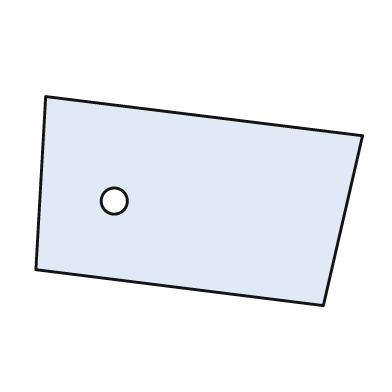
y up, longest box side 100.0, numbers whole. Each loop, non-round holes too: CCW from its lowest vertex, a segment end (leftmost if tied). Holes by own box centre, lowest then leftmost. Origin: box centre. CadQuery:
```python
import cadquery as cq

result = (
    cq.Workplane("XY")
    .moveTo(38.0, -32.0)
    .lineTo(50.0, 20.0)
    .lineTo(-47.0, 32.0)
    .lineTo(-50.0, -21.0)
    .close()
    .moveTo(-26.0, 0.0)
    .circle(4.0)
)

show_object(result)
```